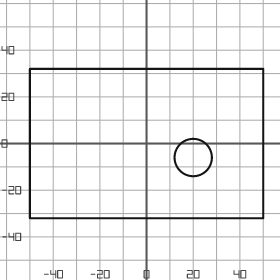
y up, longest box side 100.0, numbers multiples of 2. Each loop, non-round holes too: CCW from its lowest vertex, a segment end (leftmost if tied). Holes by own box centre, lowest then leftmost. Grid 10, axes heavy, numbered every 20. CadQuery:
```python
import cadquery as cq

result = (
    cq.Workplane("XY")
    .moveTo(-50.0, -32.0)
    .lineTo(50.0, -32.0)
    .lineTo(50.0, 32.0)
    .lineTo(-50.0, 32.0)
    .close()
    .moveTo(20.0, -6.0)
    .circle(8.0)
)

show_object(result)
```